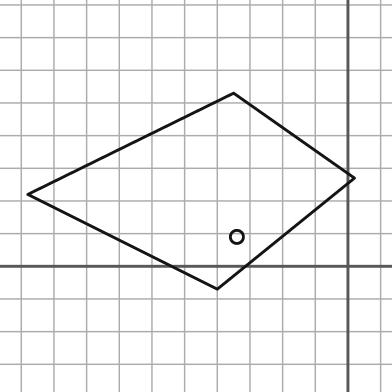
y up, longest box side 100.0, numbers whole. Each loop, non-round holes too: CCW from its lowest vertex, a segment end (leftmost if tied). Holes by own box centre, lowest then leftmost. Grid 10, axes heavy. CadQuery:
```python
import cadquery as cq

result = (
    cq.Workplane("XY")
    .moveTo(-40.0, -7.0)
    .lineTo(2.0, 27.0)
    .lineTo(-35.0, 53.0)
    .lineTo(-98.0, 22.0)
    .close()
    .moveTo(-34.0, 9.0)
    .circle(2.0)
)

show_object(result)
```